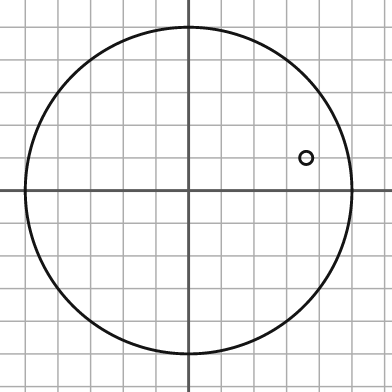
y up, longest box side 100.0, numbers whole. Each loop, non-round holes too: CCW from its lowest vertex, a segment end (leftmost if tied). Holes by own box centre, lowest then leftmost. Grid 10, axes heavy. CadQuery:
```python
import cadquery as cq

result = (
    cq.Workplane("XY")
    .moveTo(0.0, 0.0)
    .circle(50.0)
    .moveTo(36.0, 10.0)
    .circle(2.0)
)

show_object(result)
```